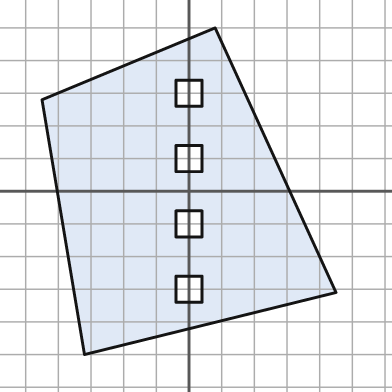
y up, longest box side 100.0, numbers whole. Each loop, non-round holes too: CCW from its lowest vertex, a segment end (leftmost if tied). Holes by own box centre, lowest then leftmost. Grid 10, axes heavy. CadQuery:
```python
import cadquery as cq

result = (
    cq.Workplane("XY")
    .moveTo(-32.0, -50.0)
    .lineTo(45.0, -31.0)
    .lineTo(8.0, 50.0)
    .lineTo(-45.0, 28.0)
    .close()
    .moveTo(-4.0, -34.0)
    .lineTo(4.0, -34.0)
    .lineTo(4.0, -26.0)
    .lineTo(-4.0, -26.0)
    .close()
    .moveTo(-4.0, -14.0)
    .lineTo(4.0, -14.0)
    .lineTo(4.0, -6.0)
    .lineTo(-4.0, -6.0)
    .close()
    .moveTo(-4.0, 6.0)
    .lineTo(4.0, 6.0)
    .lineTo(4.0, 14.0)
    .lineTo(-4.0, 14.0)
    .close()
    .moveTo(-4.0, 26.0)
    .lineTo(4.0, 26.0)
    .lineTo(4.0, 34.0)
    .lineTo(-4.0, 34.0)
    .close()
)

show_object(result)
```